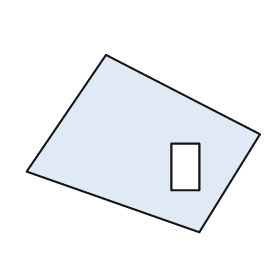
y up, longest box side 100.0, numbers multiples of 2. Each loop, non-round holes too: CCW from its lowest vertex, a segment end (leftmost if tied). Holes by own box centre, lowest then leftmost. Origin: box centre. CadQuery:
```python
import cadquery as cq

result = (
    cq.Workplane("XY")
    .moveTo(24.0, -38.0)
    .lineTo(50.0, 4.0)
    .lineTo(-16.0, 38.0)
    .lineTo(-50.0, -12.0)
    .close()
    .moveTo(12.0, -20.0)
    .lineTo(24.0, -20.0)
    .lineTo(24.0, 0.0)
    .lineTo(12.0, 0.0)
    .close()
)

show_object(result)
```